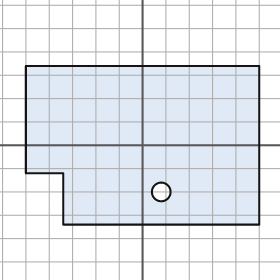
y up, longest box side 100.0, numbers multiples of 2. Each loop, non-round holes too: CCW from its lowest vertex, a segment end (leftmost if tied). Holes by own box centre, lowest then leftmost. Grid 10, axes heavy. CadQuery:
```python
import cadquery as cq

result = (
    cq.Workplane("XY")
    .moveTo(-34.0, -34.0)
    .lineTo(50.0, -34.0)
    .lineTo(50.0, 34.0)
    .lineTo(-50.0, 34.0)
    .lineTo(-50.0, -12.0)
    .lineTo(-34.0, -12.0)
    .close()
    .moveTo(8.0, -20.0)
    .circle(4.0)
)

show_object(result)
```